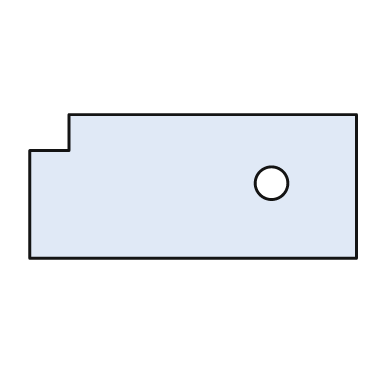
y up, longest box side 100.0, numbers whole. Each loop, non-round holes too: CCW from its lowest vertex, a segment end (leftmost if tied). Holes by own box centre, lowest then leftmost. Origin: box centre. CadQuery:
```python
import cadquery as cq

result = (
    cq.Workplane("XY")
    .moveTo(-50.0, -22.0)
    .lineTo(50.0, -22.0)
    .lineTo(50.0, 22.0)
    .lineTo(-38.0, 22.0)
    .lineTo(-38.0, 11.0)
    .lineTo(-50.0, 11.0)
    .close()
    .moveTo(24.0, 1.0)
    .circle(5.0)
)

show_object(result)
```